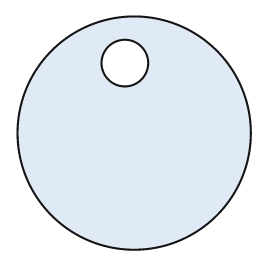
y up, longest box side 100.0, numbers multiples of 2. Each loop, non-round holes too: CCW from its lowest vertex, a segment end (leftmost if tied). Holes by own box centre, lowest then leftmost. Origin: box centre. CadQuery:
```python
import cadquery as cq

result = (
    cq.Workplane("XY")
    .moveTo(0.0, 0.0)
    .circle(50.0)
    .moveTo(-4.0, 30.0)
    .circle(10.0)
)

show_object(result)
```